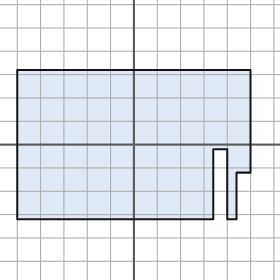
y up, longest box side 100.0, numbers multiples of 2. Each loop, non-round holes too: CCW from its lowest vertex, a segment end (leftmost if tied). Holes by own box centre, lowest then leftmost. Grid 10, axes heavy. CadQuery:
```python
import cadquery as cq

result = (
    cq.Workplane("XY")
    .moveTo(-50.0, -32.0)
    .lineTo(34.0, -32.0)
    .lineTo(34.0, -2.0)
    .lineTo(40.0, -2.0)
    .lineTo(40.0, -32.0)
    .lineTo(44.0, -32.0)
    .lineTo(44.0, -12.0)
    .lineTo(50.0, -12.0)
    .lineTo(50.0, 32.0)
    .lineTo(-50.0, 32.0)
    .close()
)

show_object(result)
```